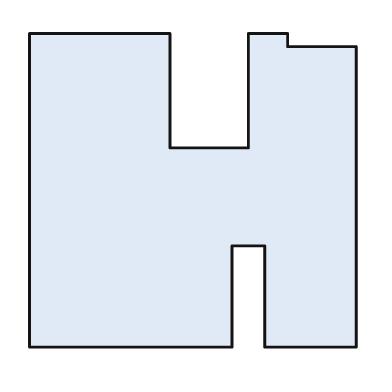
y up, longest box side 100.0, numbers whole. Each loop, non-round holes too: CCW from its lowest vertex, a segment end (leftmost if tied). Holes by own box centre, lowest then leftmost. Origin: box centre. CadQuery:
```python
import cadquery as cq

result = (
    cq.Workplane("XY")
    .moveTo(-50.0, -48.0)
    .lineTo(12.0, -48.0)
    .lineTo(12.0, -17.0)
    .lineTo(22.0, -17.0)
    .lineTo(22.0, -48.0)
    .lineTo(50.0, -48.0)
    .lineTo(50.0, 44.0)
    .lineTo(29.0, 44.0)
    .lineTo(29.0, 48.0)
    .lineTo(17.0, 48.0)
    .lineTo(17.0, 13.0)
    .lineTo(-7.0, 13.0)
    .lineTo(-7.0, 48.0)
    .lineTo(-50.0, 48.0)
    .close()
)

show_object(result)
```